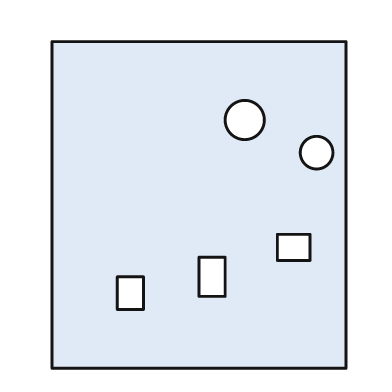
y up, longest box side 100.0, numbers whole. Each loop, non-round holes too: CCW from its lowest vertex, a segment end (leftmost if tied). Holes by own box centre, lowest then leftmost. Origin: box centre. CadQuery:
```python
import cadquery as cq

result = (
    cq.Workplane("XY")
    .moveTo(-45.0, -50.0)
    .lineTo(45.0, -50.0)
    .lineTo(45.0, 50.0)
    .lineTo(-45.0, 50.0)
    .close()
    .moveTo(-25.0, -32.0)
    .lineTo(-17.0, -32.0)
    .lineTo(-17.0, -22.0)
    .lineTo(-25.0, -22.0)
    .close()
    .moveTo(0.0, -28.0)
    .lineTo(8.0, -28.0)
    .lineTo(8.0, -16.0)
    .lineTo(0.0, -16.0)
    .close()
    .moveTo(24.0, -17.0)
    .lineTo(34.0, -17.0)
    .lineTo(34.0, -9.0)
    .lineTo(24.0, -9.0)
    .close()
    .moveTo(36.0, 16.0)
    .circle(5.0)
    .moveTo(14.0, 26.0)
    .circle(6.0)
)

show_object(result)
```